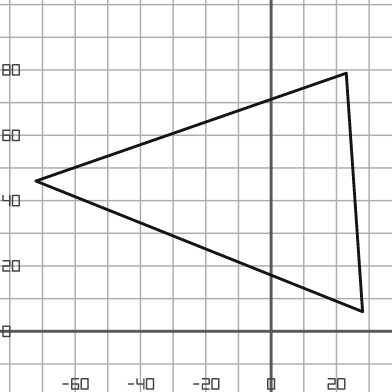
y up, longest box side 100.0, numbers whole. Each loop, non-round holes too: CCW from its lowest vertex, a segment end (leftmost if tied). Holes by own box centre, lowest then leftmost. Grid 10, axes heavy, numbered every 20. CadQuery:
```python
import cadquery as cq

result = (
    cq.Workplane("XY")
    .moveTo(28.0, 6.0)
    .lineTo(23.0, 79.0)
    .lineTo(-72.0, 46.0)
    .close()
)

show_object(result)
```